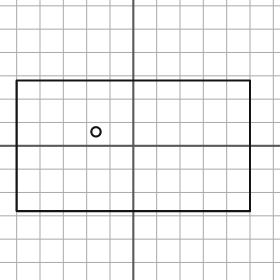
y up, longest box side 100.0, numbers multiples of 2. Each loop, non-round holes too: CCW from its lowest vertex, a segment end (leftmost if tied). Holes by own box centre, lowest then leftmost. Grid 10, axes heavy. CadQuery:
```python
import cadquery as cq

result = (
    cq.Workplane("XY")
    .moveTo(-50.0, -28.0)
    .lineTo(50.0, -28.0)
    .lineTo(50.0, 28.0)
    .lineTo(-50.0, 28.0)
    .close()
    .moveTo(-16.0, 6.0)
    .circle(2.0)
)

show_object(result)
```